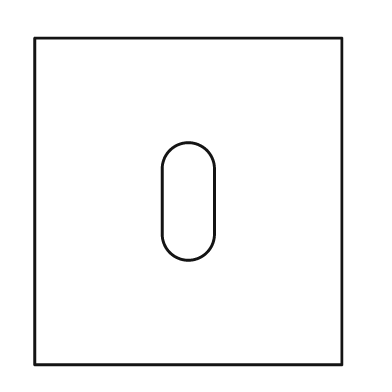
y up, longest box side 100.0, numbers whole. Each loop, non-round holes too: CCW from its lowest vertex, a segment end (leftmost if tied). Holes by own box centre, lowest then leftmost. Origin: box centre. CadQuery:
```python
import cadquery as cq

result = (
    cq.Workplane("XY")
    .moveTo(-47.0, -50.0)
    .lineTo(47.0, -50.0)
    .lineTo(47.0, 50.0)
    .lineTo(-47.0, 50.0)
    .close()
    .moveTo(-8.0, -10.0)
    .threePointArc((0.0, -18.0), (8.0, -10.0))
    .lineTo(8.0, 10.0)
    .threePointArc((0.0, 18.0), (-8.0, 10.0))
    .close()
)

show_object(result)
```